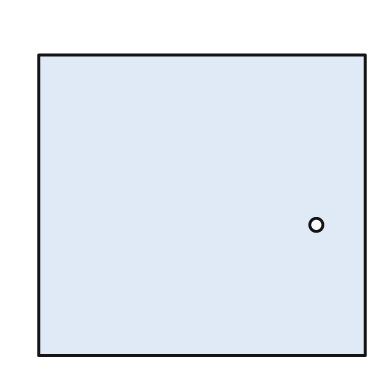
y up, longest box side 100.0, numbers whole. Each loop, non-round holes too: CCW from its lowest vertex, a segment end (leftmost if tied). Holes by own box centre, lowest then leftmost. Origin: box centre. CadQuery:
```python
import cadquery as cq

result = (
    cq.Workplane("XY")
    .moveTo(-50.0, -46.0)
    .lineTo(50.0, -46.0)
    .lineTo(50.0, 46.0)
    .lineTo(-50.0, 46.0)
    .close()
    .moveTo(35.0, -6.0)
    .circle(2.0)
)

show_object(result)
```